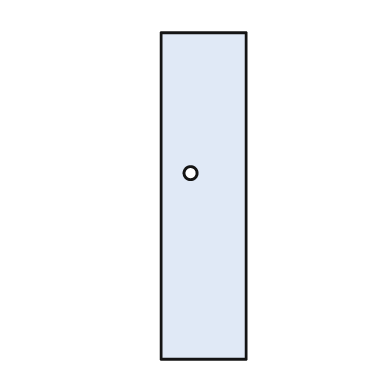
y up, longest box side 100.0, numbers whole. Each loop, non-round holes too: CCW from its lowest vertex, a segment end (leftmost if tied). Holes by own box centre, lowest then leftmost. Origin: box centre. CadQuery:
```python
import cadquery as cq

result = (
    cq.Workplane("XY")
    .moveTo(-13.0, -50.0)
    .lineTo(13.0, -50.0)
    .lineTo(13.0, 50.0)
    .lineTo(-13.0, 50.0)
    .close()
    .moveTo(-4.0, 7.0)
    .circle(2.0)
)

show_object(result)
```